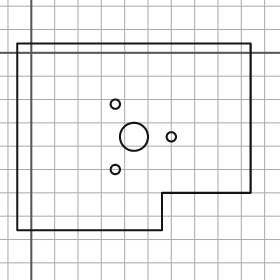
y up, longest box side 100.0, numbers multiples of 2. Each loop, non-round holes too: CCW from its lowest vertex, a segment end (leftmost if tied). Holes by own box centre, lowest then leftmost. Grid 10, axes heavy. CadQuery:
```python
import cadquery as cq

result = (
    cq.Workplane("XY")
    .moveTo(-6.0, -76.0)
    .lineTo(56.0, -76.0)
    .lineTo(56.0, -60.0)
    .lineTo(94.0, -60.0)
    .lineTo(94.0, 4.0)
    .lineTo(-6.0, 4.0)
    .close()
    .moveTo(36.0, -50.0)
    .circle(2.0)
    .moveTo(44.0, -36.0)
    .circle(6.0)
    .moveTo(60.0, -36.0)
    .circle(2.0)
    .moveTo(36.0, -22.0)
    .circle(2.0)
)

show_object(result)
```